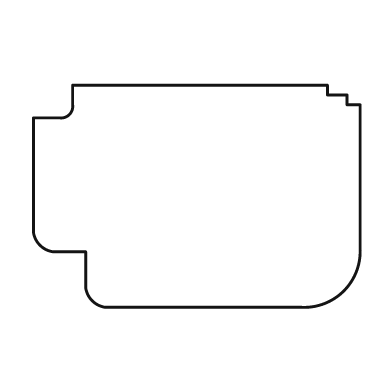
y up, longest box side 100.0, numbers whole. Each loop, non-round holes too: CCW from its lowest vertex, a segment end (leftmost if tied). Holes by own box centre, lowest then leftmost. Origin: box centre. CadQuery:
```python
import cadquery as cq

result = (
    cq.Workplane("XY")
    .moveTo(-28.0, -34.0)
    .lineTo(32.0, -34.0)
    .threePointArc((45.0, -29.0), (50.0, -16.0))
    .lineTo(50.0, 28.0)
    .lineTo(46.0, 28.0)
    .lineTo(46.0, 31.0)
    .lineTo(40.0, 31.0)
    .lineTo(40.0, 34.0)
    .lineTo(-38.0, 34.0)
    .lineTo(-38.0, 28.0)
    .threePointArc((-39.0, 25.0), (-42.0, 24.0))
    .lineTo(-50.0, 24.0)
    .lineTo(-50.0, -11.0)
    .threePointArc((-48.0, -15.0), (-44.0, -17.0))
    .lineTo(-34.0, -17.0)
    .lineTo(-34.0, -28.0)
    .threePointArc((-32.0, -32.0), (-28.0, -34.0))
    .close()
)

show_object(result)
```